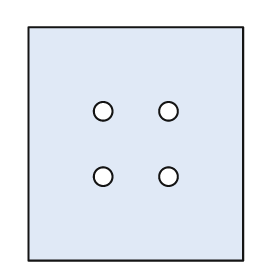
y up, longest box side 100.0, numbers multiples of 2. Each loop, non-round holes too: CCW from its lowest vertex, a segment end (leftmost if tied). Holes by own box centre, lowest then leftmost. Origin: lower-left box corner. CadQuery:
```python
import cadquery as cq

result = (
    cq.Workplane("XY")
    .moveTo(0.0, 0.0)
    .lineTo(92.0, 0.0)
    .lineTo(92.0, 100.0)
    .lineTo(0.0, 100.0)
    .close()
    .moveTo(32.0, 36.0)
    .circle(4.0)
    .moveTo(60.0, 36.0)
    .circle(4.0)
    .moveTo(32.0, 64.0)
    .circle(4.0)
    .moveTo(60.0, 64.0)
    .circle(4.0)
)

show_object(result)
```